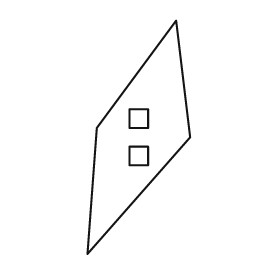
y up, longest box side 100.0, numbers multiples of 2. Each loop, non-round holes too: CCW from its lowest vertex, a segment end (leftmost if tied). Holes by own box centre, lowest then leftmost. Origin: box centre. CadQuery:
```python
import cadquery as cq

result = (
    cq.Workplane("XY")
    .moveTo(-22.0, -50.0)
    .lineTo(22.0, 0.0)
    .lineTo(16.0, 50.0)
    .lineTo(-18.0, 4.0)
    .close()
    .moveTo(-4.0, -12.0)
    .lineTo(4.0, -12.0)
    .lineTo(4.0, -4.0)
    .lineTo(-4.0, -4.0)
    .close()
    .moveTo(-4.0, 4.0)
    .lineTo(4.0, 4.0)
    .lineTo(4.0, 12.0)
    .lineTo(-4.0, 12.0)
    .close()
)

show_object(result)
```